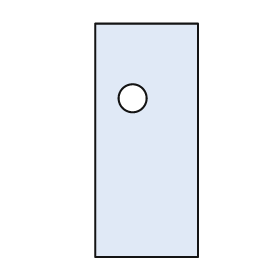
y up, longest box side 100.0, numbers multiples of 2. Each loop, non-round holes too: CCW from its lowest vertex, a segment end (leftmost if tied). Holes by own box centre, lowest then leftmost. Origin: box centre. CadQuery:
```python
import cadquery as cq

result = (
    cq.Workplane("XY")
    .moveTo(-22.0, -50.0)
    .lineTo(22.0, -50.0)
    .lineTo(22.0, 50.0)
    .lineTo(-22.0, 50.0)
    .close()
    .moveTo(-6.0, 18.0)
    .circle(6.0)
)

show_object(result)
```